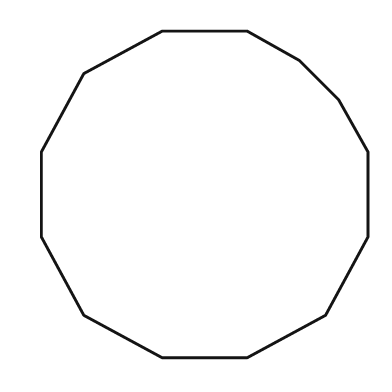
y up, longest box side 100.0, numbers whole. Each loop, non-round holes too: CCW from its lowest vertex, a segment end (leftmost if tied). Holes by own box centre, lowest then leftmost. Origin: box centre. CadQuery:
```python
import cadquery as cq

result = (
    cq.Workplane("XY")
    .moveTo(-13.0, -50.0)
    .lineTo(13.0, -50.0)
    .lineTo(37.0, -37.0)
    .lineTo(50.0, -13.0)
    .lineTo(50.0, 13.0)
    .lineTo(41.0, 29.0)
    .lineTo(29.0, 41.0)
    .lineTo(13.0, 50.0)
    .lineTo(-13.0, 50.0)
    .lineTo(-37.0, 37.0)
    .lineTo(-50.0, 13.0)
    .lineTo(-50.0, -13.0)
    .lineTo(-37.0, -37.0)
    .close()
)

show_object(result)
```